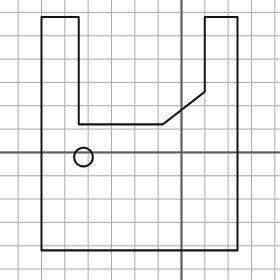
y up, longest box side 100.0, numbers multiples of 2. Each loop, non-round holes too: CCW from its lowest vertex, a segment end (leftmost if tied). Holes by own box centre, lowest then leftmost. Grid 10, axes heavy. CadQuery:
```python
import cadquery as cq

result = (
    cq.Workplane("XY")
    .moveTo(-60.0, -42.0)
    .lineTo(24.0, -42.0)
    .lineTo(24.0, 58.0)
    .lineTo(10.0, 58.0)
    .lineTo(10.0, 26.0)
    .lineTo(-8.0, 12.0)
    .lineTo(-44.0, 12.0)
    .lineTo(-44.0, 58.0)
    .lineTo(-60.0, 58.0)
    .close()
    .moveTo(-42.0, -2.0)
    .circle(4.0)
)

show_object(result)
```